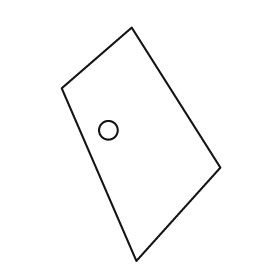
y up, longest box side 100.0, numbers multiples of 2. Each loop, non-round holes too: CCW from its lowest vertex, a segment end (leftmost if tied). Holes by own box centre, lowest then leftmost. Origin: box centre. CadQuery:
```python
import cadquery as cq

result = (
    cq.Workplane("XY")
    .moveTo(-2.0, -50.0)
    .lineTo(34.0, -10.0)
    .lineTo(-4.0, 50.0)
    .lineTo(-34.0, 24.0)
    .close()
    .moveTo(-14.0, 6.0)
    .circle(4.0)
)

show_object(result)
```